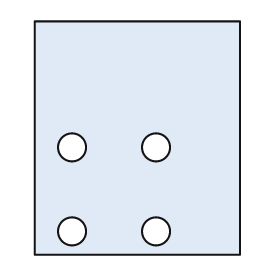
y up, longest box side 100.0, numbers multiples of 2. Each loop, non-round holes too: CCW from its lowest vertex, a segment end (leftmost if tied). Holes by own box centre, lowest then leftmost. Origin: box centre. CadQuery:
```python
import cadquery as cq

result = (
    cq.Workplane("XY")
    .moveTo(-44.0, -50.0)
    .lineTo(44.0, -50.0)
    .lineTo(44.0, 50.0)
    .lineTo(-44.0, 50.0)
    .close()
    .moveTo(-28.0, -40.0)
    .circle(6.0)
    .moveTo(8.0, -40.0)
    .circle(6.0)
    .moveTo(-28.0, -4.0)
    .circle(6.0)
    .moveTo(8.0, -4.0)
    .circle(6.0)
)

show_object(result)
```